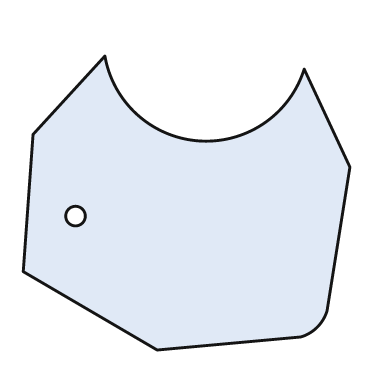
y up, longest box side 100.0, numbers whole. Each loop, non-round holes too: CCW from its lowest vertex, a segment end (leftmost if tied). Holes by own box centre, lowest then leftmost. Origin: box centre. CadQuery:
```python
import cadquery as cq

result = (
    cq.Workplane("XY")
    .moveTo(-9.0, -45.0)
    .lineTo(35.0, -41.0)
    .threePointArc((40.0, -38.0), (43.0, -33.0))
    .lineTo(50.0, 11.0)
    .lineTo(36.0, 41.0)
    .threePointArc((4.0, 19.0), (-25.0, 45.0))
    .lineTo(-47.0, 21.0)
    .lineTo(-50.0, -21.0)
    .close()
    .moveTo(-34.0, -4.0)
    .circle(3.0)
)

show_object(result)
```